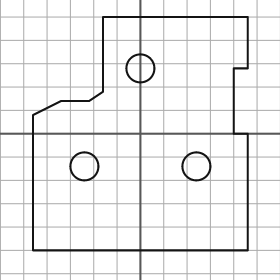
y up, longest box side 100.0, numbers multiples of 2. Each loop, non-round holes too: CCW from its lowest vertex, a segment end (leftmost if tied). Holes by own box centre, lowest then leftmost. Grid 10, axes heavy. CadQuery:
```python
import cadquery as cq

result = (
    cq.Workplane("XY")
    .moveTo(-46.0, -50.0)
    .lineTo(46.0, -50.0)
    .lineTo(46.0, 0.0)
    .lineTo(40.0, 0.0)
    .lineTo(40.0, 28.0)
    .lineTo(46.0, 28.0)
    .lineTo(46.0, 50.0)
    .lineTo(-16.0, 50.0)
    .lineTo(-16.0, 18.0)
    .lineTo(-22.0, 14.0)
    .lineTo(-34.0, 14.0)
    .lineTo(-46.0, 8.0)
    .close()
    .moveTo(-24.0, -14.0)
    .circle(6.0)
    .moveTo(24.0, -14.0)
    .circle(6.0)
    .moveTo(0.0, 28.0)
    .circle(6.0)
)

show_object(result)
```